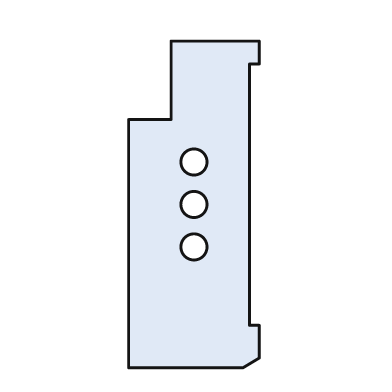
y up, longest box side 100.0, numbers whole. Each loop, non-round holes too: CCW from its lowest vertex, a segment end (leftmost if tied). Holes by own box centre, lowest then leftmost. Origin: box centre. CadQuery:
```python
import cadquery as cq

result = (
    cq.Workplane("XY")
    .moveTo(-20.0, -50.0)
    .lineTo(15.0, -50.0)
    .lineTo(20.0, -47.0)
    .lineTo(20.0, -37.0)
    .lineTo(17.0, -37.0)
    .lineTo(17.0, 43.0)
    .lineTo(20.0, 43.0)
    .lineTo(20.0, 50.0)
    .lineTo(-7.0, 50.0)
    .lineTo(-7.0, 26.0)
    .lineTo(-20.0, 26.0)
    .close()
    .moveTo(0.0, -13.0)
    .circle(4.0)
    .moveTo(0.0, 0.0)
    .circle(4.0)
    .moveTo(0.0, 13.0)
    .circle(4.0)
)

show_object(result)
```